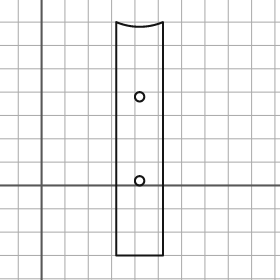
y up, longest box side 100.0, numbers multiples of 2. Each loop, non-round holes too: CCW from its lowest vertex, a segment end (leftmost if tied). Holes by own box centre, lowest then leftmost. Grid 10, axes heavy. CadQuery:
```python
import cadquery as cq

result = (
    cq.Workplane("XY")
    .moveTo(32.0, -30.0)
    .lineTo(52.0, -30.0)
    .lineTo(52.0, 70.0)
    .threePointArc((42.0, 68.0), (32.0, 70.0))
    .close()
    .moveTo(42.0, 2.0)
    .circle(2.0)
    .moveTo(42.0, 38.0)
    .circle(2.0)
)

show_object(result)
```